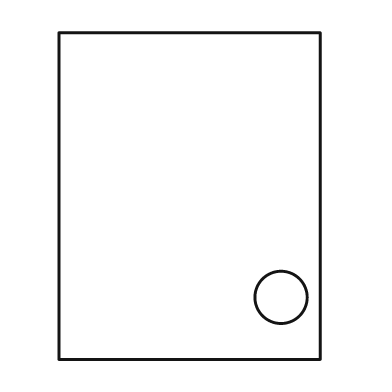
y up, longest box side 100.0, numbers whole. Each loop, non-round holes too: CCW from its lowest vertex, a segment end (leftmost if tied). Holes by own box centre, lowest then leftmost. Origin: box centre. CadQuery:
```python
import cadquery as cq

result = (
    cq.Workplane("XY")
    .moveTo(-40.0, -50.0)
    .lineTo(40.0, -50.0)
    .lineTo(40.0, 50.0)
    .lineTo(-40.0, 50.0)
    .close()
    .moveTo(28.0, -31.0)
    .circle(8.0)
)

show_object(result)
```